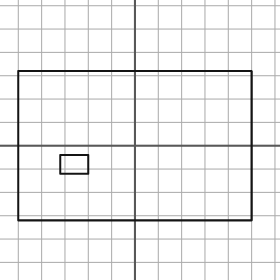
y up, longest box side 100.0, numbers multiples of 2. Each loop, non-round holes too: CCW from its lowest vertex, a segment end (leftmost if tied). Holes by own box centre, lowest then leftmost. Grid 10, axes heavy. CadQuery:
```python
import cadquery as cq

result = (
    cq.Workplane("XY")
    .moveTo(-50.0, -32.0)
    .lineTo(50.0, -32.0)
    .lineTo(50.0, 32.0)
    .lineTo(-50.0, 32.0)
    .close()
    .moveTo(-32.0, -12.0)
    .lineTo(-20.0, -12.0)
    .lineTo(-20.0, -4.0)
    .lineTo(-32.0, -4.0)
    .close()
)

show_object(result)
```